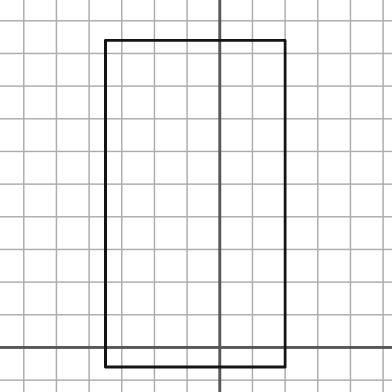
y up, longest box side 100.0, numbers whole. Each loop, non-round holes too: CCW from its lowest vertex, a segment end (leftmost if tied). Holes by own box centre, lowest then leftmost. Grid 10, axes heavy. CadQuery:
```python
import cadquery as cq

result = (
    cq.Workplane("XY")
    .moveTo(-35.0, -6.0)
    .lineTo(20.0, -6.0)
    .lineTo(20.0, 94.0)
    .lineTo(-35.0, 94.0)
    .close()
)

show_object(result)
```